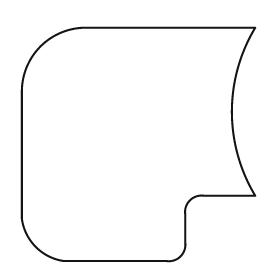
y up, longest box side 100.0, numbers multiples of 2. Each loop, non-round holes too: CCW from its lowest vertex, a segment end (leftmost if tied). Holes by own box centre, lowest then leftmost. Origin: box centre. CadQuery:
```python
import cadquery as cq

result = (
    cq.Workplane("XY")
    .moveTo(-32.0, -50.0)
    .lineTo(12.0, -50.0)
    .threePointArc((18.0, -48.0), (20.0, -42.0))
    .lineTo(20.0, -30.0)
    .threePointArc((22.0, -24.0), (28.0, -22.0))
    .lineTo(50.0, -22.0)
    .threePointArc((40.0, 14.0), (50.0, 50.0))
    .lineTo(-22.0, 50.0)
    .threePointArc((-42.0, 42.0), (-50.0, 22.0))
    .lineTo(-50.0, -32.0)
    .threePointArc((-44.0, -44.0), (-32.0, -50.0))
    .close()
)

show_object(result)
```